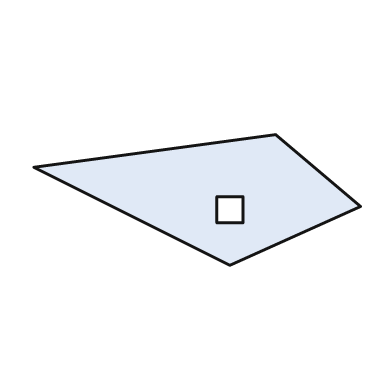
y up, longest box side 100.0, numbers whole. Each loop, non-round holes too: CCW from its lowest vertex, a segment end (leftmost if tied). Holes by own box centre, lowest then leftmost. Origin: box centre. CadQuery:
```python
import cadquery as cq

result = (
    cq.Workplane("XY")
    .moveTo(10.0, -20.0)
    .lineTo(50.0, -2.0)
    .lineTo(24.0, 20.0)
    .lineTo(-50.0, 10.0)
    .close()
    .moveTo(6.0, -7.0)
    .lineTo(14.0, -7.0)
    .lineTo(14.0, 1.0)
    .lineTo(6.0, 1.0)
    .close()
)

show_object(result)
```